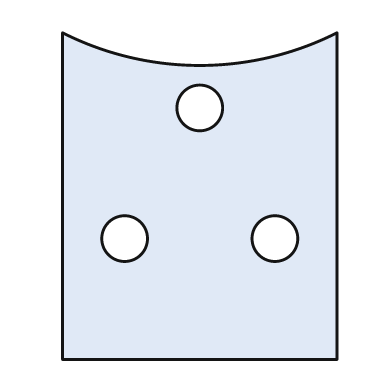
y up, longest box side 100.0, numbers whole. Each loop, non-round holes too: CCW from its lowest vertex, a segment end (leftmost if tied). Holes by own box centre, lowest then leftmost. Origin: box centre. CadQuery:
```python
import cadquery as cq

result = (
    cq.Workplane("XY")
    .moveTo(-42.0, -50.0)
    .lineTo(42.0, -50.0)
    .lineTo(42.0, 50.0)
    .threePointArc((0.0, 40.0), (-42.0, 50.0))
    .close()
    .moveTo(-23.0, -13.0)
    .circle(7.0)
    .moveTo(23.0, -13.0)
    .circle(7.0)
    .moveTo(0.0, 27.0)
    .circle(7.0)
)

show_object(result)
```